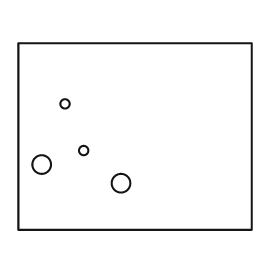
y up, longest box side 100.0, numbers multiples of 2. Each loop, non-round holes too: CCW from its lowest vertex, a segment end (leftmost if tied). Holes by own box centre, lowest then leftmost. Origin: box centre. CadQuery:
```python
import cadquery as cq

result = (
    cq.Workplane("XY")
    .moveTo(-50.0, -40.0)
    .lineTo(50.0, -40.0)
    .lineTo(50.0, 40.0)
    .lineTo(-50.0, 40.0)
    .close()
    .moveTo(-6.0, -20.0)
    .circle(4.0)
    .moveTo(-40.0, -12.0)
    .circle(4.0)
    .moveTo(-22.0, -6.0)
    .circle(2.0)
    .moveTo(-30.0, 14.0)
    .circle(2.0)
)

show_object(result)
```